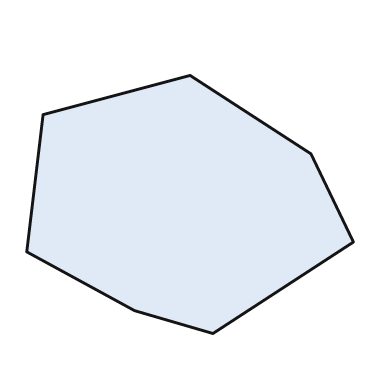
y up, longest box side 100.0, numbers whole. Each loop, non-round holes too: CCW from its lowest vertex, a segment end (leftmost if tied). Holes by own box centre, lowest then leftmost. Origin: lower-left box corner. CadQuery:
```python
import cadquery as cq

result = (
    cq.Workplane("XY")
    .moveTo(57.0, 0.0)
    .lineTo(100.0, 28.0)
    .lineTo(87.0, 55.0)
    .lineTo(50.0, 79.0)
    .lineTo(5.0, 67.0)
    .lineTo(0.0, 25.0)
    .lineTo(33.0, 7.0)
    .close()
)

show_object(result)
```